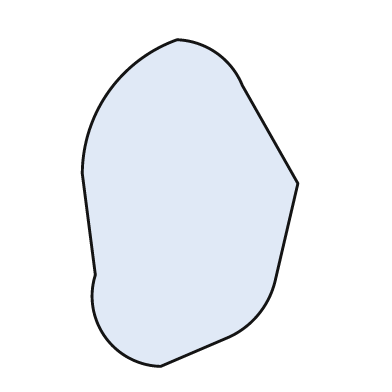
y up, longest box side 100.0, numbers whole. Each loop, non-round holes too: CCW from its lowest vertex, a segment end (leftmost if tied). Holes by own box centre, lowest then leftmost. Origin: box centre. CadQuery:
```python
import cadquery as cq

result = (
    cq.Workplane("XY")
    .moveTo(-9.0, -50.0)
    .lineTo(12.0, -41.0)
    .threePointArc((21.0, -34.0), (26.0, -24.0))
    .lineTo(33.0, 6.0)
    .lineTo(16.0, 36.0)
    .threePointArc((8.0, 46.0), (-4.0, 50.0))
    .threePointArc((-25.0, 34.0), (-33.0, 9.0))
    .lineTo(-29.0, -22.0)
    .threePointArc((-26.0, -41.0), (-9.0, -50.0))
    .close()
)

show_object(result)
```